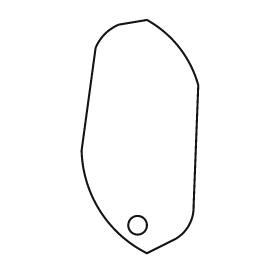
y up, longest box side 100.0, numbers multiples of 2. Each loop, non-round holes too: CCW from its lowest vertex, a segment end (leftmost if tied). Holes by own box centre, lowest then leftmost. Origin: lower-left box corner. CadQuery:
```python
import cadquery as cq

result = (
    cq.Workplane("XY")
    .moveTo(28.0, 0.0)
    .lineTo(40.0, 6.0)
    .threePointArc((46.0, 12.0), (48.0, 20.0))
    .lineTo(50.0, 72.0)
    .threePointArc((42.0, 88.0), (28.0, 100.0))
    .lineTo(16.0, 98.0)
    .threePointArc((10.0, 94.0), (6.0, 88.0))
    .lineTo(0.0, 44.0)
    .threePointArc((8.0, 18.0), (28.0, 0.0))
    .close()
    .moveTo(24.0, 12.0)
    .circle(4.0)
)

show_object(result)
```